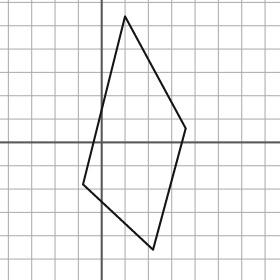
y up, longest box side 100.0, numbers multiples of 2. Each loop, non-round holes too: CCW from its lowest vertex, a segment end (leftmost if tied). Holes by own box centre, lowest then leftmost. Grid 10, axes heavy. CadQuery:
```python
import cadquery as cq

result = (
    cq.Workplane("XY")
    .moveTo(22.0, -46.0)
    .lineTo(36.0, 6.0)
    .lineTo(10.0, 54.0)
    .lineTo(-8.0, -18.0)
    .close()
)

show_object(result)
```